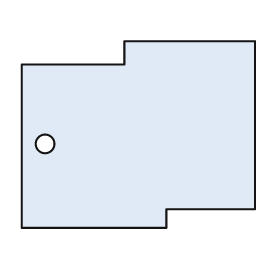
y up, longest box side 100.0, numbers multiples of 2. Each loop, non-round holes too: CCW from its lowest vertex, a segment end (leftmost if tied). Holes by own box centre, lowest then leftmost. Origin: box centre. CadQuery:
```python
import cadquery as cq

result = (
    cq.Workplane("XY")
    .moveTo(-50.0, -40.0)
    .lineTo(12.0, -40.0)
    .lineTo(12.0, -32.0)
    .lineTo(50.0, -32.0)
    .lineTo(50.0, 40.0)
    .lineTo(-6.0, 40.0)
    .lineTo(-6.0, 30.0)
    .lineTo(-50.0, 30.0)
    .close()
    .moveTo(-40.0, -4.0)
    .circle(4.0)
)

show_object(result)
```